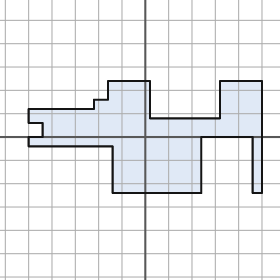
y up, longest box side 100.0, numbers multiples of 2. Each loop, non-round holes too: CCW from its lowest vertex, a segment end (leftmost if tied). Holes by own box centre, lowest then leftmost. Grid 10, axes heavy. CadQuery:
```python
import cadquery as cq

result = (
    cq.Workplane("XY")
    .moveTo(-14.0, -24.0)
    .lineTo(24.0, -24.0)
    .lineTo(24.0, 0.0)
    .lineTo(46.0, 0.0)
    .lineTo(46.0, -24.0)
    .lineTo(50.0, -24.0)
    .lineTo(50.0, 24.0)
    .lineTo(32.0, 24.0)
    .lineTo(32.0, 8.0)
    .lineTo(2.0, 8.0)
    .lineTo(2.0, 24.0)
    .lineTo(-16.0, 24.0)
    .lineTo(-16.0, 16.0)
    .lineTo(-22.0, 16.0)
    .lineTo(-22.0, 12.0)
    .lineTo(-50.0, 12.0)
    .lineTo(-50.0, 6.0)
    .lineTo(-44.0, 6.0)
    .lineTo(-44.0, 0.0)
    .lineTo(-50.0, 0.0)
    .lineTo(-50.0, -4.0)
    .lineTo(-14.0, -4.0)
    .close()
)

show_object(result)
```